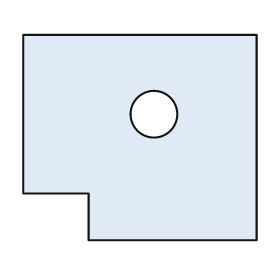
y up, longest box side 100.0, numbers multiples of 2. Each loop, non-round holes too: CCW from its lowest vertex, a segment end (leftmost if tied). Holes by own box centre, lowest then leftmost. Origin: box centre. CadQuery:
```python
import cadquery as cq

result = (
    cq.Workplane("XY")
    .moveTo(-22.0, -44.0)
    .lineTo(50.0, -44.0)
    .lineTo(50.0, 44.0)
    .lineTo(-50.0, 44.0)
    .lineTo(-50.0, -24.0)
    .lineTo(-22.0, -24.0)
    .close()
    .moveTo(6.0, 10.0)
    .circle(10.0)
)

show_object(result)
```